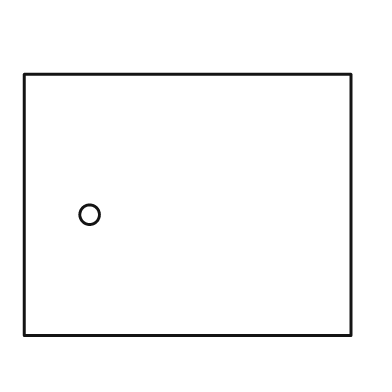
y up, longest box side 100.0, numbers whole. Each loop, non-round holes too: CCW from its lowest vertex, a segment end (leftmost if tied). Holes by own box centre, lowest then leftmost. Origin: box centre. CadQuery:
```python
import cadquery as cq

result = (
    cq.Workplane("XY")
    .moveTo(-50.0, -40.0)
    .lineTo(50.0, -40.0)
    .lineTo(50.0, 40.0)
    .lineTo(-50.0, 40.0)
    .close()
    .moveTo(-30.0, -3.0)
    .circle(3.0)
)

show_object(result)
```